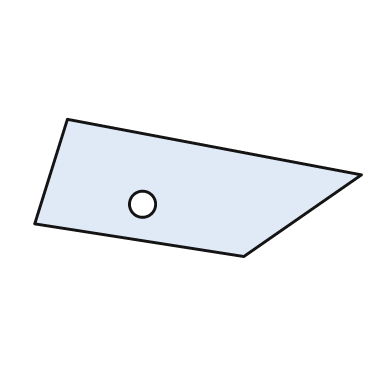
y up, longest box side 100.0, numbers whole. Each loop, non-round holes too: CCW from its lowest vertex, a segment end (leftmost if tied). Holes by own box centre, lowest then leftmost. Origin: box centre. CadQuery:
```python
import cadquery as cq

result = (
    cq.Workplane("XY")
    .moveTo(14.0, -21.0)
    .lineTo(50.0, 4.0)
    .lineTo(-40.0, 21.0)
    .lineTo(-50.0, -11.0)
    .close()
    .moveTo(-17.0, -5.0)
    .circle(4.0)
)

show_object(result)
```